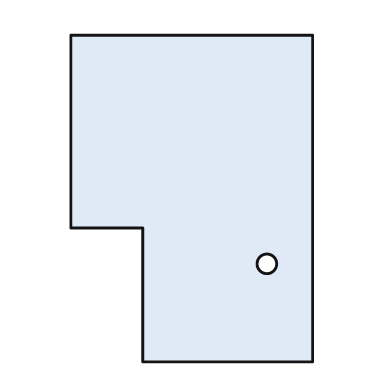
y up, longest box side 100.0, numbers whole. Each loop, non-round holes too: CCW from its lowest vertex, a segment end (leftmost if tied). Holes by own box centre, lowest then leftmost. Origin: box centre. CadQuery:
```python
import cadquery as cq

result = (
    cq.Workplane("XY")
    .moveTo(-15.0, -50.0)
    .lineTo(37.0, -50.0)
    .lineTo(37.0, 50.0)
    .lineTo(-37.0, 50.0)
    .lineTo(-37.0, -9.0)
    .lineTo(-15.0, -9.0)
    .close()
    .moveTo(23.0, -20.0)
    .circle(3.0)
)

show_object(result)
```